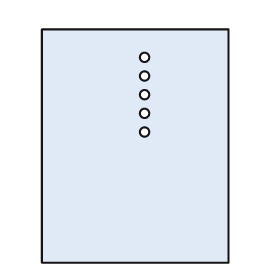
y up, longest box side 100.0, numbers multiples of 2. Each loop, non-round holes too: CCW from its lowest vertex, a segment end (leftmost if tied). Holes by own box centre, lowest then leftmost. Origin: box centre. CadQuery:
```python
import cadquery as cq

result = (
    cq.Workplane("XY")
    .moveTo(-40.0, -50.0)
    .lineTo(40.0, -50.0)
    .lineTo(40.0, 50.0)
    .lineTo(-40.0, 50.0)
    .close()
    .moveTo(4.0, 6.0)
    .circle(2.0)
    .moveTo(4.0, 14.0)
    .circle(2.0)
    .moveTo(4.0, 22.0)
    .circle(2.0)
    .moveTo(4.0, 30.0)
    .circle(2.0)
    .moveTo(4.0, 38.0)
    .circle(2.0)
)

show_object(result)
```